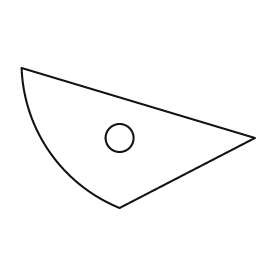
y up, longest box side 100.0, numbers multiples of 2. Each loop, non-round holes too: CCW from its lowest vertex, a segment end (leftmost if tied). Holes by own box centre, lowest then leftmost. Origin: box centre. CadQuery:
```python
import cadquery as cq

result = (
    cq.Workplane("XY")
    .moveTo(-8.0, -30.0)
    .lineTo(50.0, 0.0)
    .lineTo(-50.0, 30.0)
    .threePointArc((-38.0, -6.0), (-8.0, -30.0))
    .close()
    .moveTo(-8.0, 0.0)
    .circle(6.0)
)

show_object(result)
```